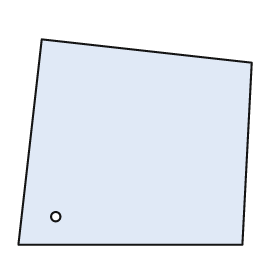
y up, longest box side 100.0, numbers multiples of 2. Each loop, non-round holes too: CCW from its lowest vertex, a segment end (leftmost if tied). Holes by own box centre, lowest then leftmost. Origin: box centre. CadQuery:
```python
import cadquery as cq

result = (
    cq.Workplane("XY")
    .moveTo(-50.0, -44.0)
    .lineTo(46.0, -44.0)
    .lineTo(50.0, 34.0)
    .lineTo(-40.0, 44.0)
    .close()
    .moveTo(-34.0, -32.0)
    .circle(2.0)
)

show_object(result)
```